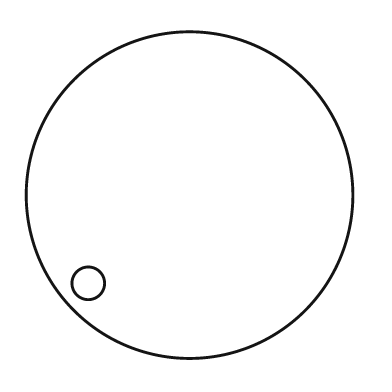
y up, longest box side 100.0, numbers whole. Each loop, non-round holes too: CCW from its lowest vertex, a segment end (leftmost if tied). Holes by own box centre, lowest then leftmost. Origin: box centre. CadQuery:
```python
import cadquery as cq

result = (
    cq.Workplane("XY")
    .moveTo(0.0, 0.0)
    .circle(50.0)
    .moveTo(-31.0, -27.0)
    .circle(5.0)
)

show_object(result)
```